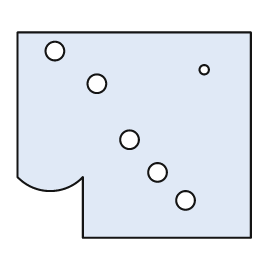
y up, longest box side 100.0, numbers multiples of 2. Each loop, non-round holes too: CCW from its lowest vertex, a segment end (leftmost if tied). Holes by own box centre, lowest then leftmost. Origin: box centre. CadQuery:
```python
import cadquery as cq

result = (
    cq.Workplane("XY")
    .moveTo(-22.0, -44.0)
    .lineTo(50.0, -44.0)
    .lineTo(50.0, 44.0)
    .lineTo(-50.0, 44.0)
    .lineTo(-50.0, -18.0)
    .threePointArc((-36.0, -24.0), (-22.0, -18.0))
    .close()
    .moveTo(22.0, -28.0)
    .circle(4.0)
    .moveTo(10.0, -16.0)
    .circle(4.0)
    .moveTo(-2.0, -2.0)
    .circle(4.0)
    .moveTo(-16.0, 22.0)
    .circle(4.0)
    .moveTo(30.0, 28.0)
    .circle(2.0)
    .moveTo(-34.0, 36.0)
    .circle(4.0)
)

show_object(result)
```